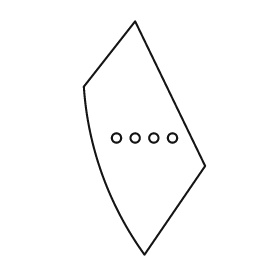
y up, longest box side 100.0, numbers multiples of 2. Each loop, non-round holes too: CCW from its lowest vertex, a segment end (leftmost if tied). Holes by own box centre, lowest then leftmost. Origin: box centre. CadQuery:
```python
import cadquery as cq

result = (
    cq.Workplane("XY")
    .moveTo(0.0, -50.0)
    .lineTo(26.0, -12.0)
    .lineTo(-4.0, 50.0)
    .lineTo(-26.0, 22.0)
    .threePointArc((-18.0, -16.0), (0.0, -50.0))
    .close()
    .moveTo(-12.0, 0.0)
    .circle(2.0)
    .moveTo(-4.0, 0.0)
    .circle(2.0)
    .moveTo(4.0, 0.0)
    .circle(2.0)
    .moveTo(12.0, 0.0)
    .circle(2.0)
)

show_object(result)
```